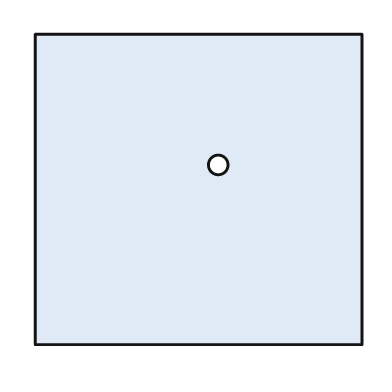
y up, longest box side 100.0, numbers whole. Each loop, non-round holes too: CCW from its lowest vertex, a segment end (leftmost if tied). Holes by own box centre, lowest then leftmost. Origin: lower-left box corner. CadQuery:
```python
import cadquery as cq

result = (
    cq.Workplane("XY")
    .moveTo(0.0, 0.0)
    .lineTo(100.0, 0.0)
    .lineTo(100.0, 95.0)
    .lineTo(0.0, 95.0)
    .close()
    .moveTo(56.0, 55.0)
    .circle(3.0)
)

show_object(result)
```